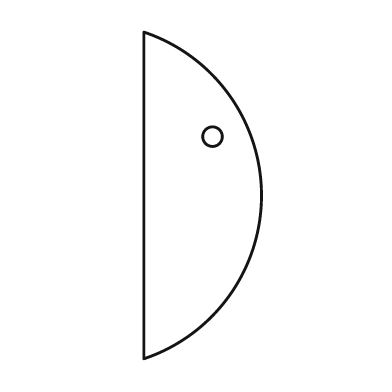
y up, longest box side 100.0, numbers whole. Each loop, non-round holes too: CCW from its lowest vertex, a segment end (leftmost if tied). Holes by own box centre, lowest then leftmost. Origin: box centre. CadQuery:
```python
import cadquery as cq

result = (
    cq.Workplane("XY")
    .moveTo(-18.0, -50.0)
    .threePointArc((18.0, 0.0), (-18.0, 50.0))
    .close()
    .moveTo(3.0, 18.0)
    .circle(3.0)
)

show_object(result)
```